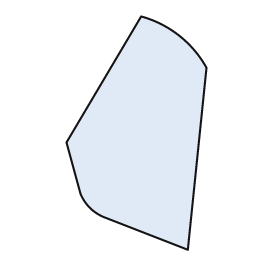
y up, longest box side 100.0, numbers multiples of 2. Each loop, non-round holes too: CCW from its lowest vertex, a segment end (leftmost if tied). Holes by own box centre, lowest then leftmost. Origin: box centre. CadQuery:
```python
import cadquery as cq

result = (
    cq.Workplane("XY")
    .moveTo(22.0, -50.0)
    .lineTo(30.0, 28.0)
    .threePointArc((18.0, 42.0), (2.0, 50.0))
    .lineTo(-30.0, -4.0)
    .lineTo(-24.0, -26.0)
    .threePointArc((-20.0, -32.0), (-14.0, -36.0))
    .close()
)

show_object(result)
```